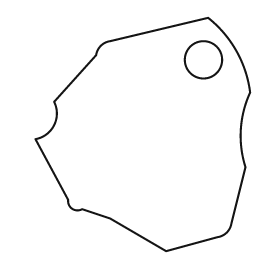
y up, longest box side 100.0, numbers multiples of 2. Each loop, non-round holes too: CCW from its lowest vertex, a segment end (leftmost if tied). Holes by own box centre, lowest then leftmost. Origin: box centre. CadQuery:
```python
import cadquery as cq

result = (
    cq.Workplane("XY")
    .moveTo(10.0, -50.0)
    .lineTo(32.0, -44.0)
    .threePointArc((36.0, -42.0), (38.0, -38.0))
    .lineTo(44.0, -14.0)
    .threePointArc((42.0, 2.0), (46.0, 18.0))
    .threePointArc((40.0, 36.0), (28.0, 50.0))
    .lineTo(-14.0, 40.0)
    .threePointArc((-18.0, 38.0), (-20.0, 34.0))
    .lineTo(-38.0, 14.0)
    .threePointArc((-38.0, 4.0), (-46.0, -2.0))
    .lineTo(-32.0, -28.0)
    .threePointArc((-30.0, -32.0), (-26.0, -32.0))
    .lineTo(-14.0, -36.0)
    .close()
    .moveTo(26.0, 32.0)
    .circle(8.0)
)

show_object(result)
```